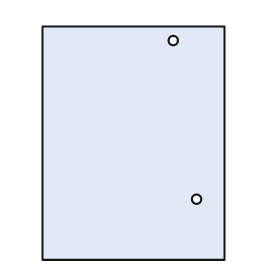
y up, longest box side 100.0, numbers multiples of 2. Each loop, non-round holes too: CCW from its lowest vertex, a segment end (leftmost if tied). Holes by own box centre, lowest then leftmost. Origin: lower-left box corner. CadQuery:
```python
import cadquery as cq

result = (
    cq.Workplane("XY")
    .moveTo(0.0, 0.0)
    .lineTo(78.0, 0.0)
    .lineTo(78.0, 100.0)
    .lineTo(0.0, 100.0)
    .close()
    .moveTo(66.0, 26.0)
    .circle(2.0)
    .moveTo(56.0, 94.0)
    .circle(2.0)
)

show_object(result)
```